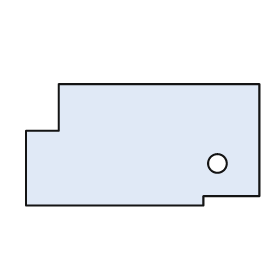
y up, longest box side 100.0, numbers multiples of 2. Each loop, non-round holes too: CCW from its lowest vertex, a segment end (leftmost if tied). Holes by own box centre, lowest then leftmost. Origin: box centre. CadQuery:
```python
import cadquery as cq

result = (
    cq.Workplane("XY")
    .moveTo(-50.0, -26.0)
    .lineTo(26.0, -26.0)
    .lineTo(26.0, -22.0)
    .lineTo(50.0, -22.0)
    .lineTo(50.0, 26.0)
    .lineTo(-36.0, 26.0)
    .lineTo(-36.0, 6.0)
    .lineTo(-50.0, 6.0)
    .close()
    .moveTo(32.0, -8.0)
    .circle(4.0)
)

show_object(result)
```